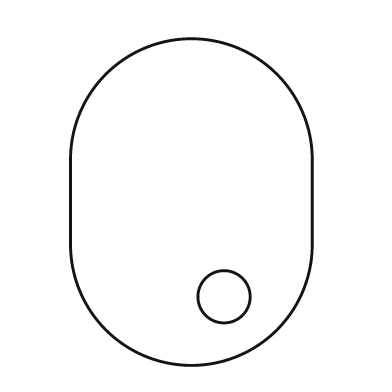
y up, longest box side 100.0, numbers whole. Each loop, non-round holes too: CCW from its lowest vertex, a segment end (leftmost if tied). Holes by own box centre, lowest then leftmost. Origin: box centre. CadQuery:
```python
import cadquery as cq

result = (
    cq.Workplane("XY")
    .moveTo(-37.0, -13.0)
    .threePointArc((0.0, -50.0), (37.0, -13.0))
    .lineTo(37.0, 13.0)
    .threePointArc((0.0, 50.0), (-37.0, 13.0))
    .close()
    .moveTo(10.0, -29.0)
    .circle(8.0)
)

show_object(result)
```